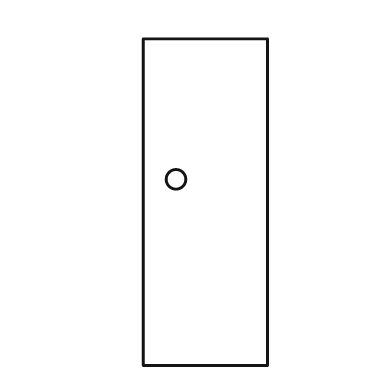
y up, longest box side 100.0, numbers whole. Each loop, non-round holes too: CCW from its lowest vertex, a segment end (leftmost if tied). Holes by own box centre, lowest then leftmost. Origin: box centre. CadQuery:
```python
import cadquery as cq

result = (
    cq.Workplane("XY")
    .moveTo(-19.0, -50.0)
    .lineTo(19.0, -50.0)
    .lineTo(19.0, 50.0)
    .lineTo(-19.0, 50.0)
    .close()
    .moveTo(-9.0, 7.0)
    .circle(3.0)
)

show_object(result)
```